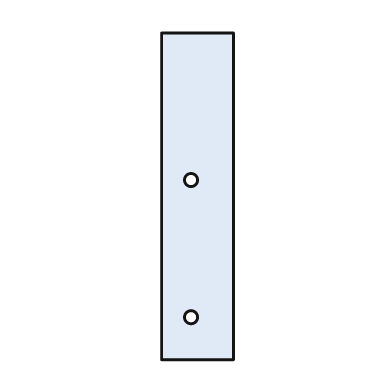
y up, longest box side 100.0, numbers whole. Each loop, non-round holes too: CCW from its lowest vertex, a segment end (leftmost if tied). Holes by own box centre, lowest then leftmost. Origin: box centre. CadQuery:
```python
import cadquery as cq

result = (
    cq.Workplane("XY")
    .moveTo(-11.0, -50.0)
    .lineTo(11.0, -50.0)
    .lineTo(11.0, 50.0)
    .lineTo(-11.0, 50.0)
    .close()
    .moveTo(-2.0, -37.0)
    .circle(2.0)
    .moveTo(-2.0, 5.0)
    .circle(2.0)
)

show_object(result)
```